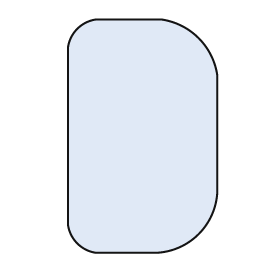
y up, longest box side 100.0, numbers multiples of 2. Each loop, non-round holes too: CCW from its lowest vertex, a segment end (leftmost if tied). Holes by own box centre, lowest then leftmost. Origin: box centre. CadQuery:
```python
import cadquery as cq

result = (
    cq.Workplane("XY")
    .moveTo(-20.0, -50.0)
    .lineTo(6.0, -50.0)
    .threePointArc((24.0, -42.0), (32.0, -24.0))
    .lineTo(32.0, 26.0)
    .threePointArc((24.0, 42.0), (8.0, 50.0))
    .lineTo(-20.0, 50.0)
    .threePointArc((-28.0, 46.0), (-32.0, 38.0))
    .lineTo(-32.0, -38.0)
    .threePointArc((-28.0, -46.0), (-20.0, -50.0))
    .close()
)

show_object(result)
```